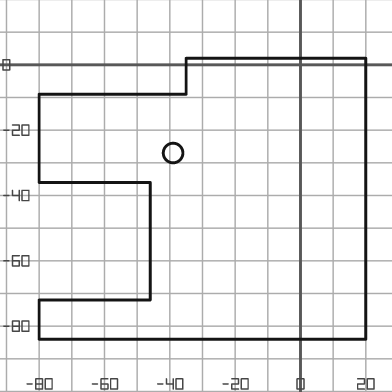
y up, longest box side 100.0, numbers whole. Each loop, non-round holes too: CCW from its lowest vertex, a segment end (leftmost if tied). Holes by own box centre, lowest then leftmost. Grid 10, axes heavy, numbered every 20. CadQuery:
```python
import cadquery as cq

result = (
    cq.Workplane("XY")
    .moveTo(-80.0, -84.0)
    .lineTo(20.0, -84.0)
    .lineTo(20.0, 2.0)
    .lineTo(-35.0, 2.0)
    .lineTo(-35.0, -9.0)
    .lineTo(-80.0, -9.0)
    .lineTo(-80.0, -36.0)
    .lineTo(-46.0, -36.0)
    .lineTo(-46.0, -72.0)
    .lineTo(-80.0, -72.0)
    .close()
    .moveTo(-39.0, -27.0)
    .circle(3.0)
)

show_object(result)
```